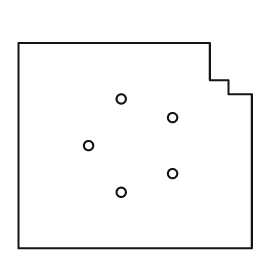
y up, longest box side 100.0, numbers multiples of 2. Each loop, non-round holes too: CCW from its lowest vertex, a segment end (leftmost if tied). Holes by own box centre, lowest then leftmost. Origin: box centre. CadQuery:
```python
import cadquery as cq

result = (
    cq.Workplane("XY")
    .moveTo(-50.0, -44.0)
    .lineTo(50.0, -44.0)
    .lineTo(50.0, 22.0)
    .lineTo(40.0, 22.0)
    .lineTo(40.0, 28.0)
    .lineTo(32.0, 28.0)
    .lineTo(32.0, 44.0)
    .lineTo(-50.0, 44.0)
    .close()
    .moveTo(-6.0, -20.0)
    .circle(2.0)
    .moveTo(16.0, -12.0)
    .circle(2.0)
    .moveTo(-20.0, 0.0)
    .circle(2.0)
    .moveTo(16.0, 12.0)
    .circle(2.0)
    .moveTo(-6.0, 20.0)
    .circle(2.0)
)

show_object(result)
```